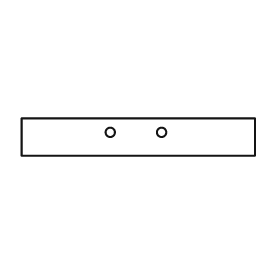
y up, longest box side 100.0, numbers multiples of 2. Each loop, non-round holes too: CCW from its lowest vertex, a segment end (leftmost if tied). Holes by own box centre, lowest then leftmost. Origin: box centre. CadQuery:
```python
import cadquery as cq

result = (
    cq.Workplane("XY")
    .moveTo(-50.0, -8.0)
    .lineTo(50.0, -8.0)
    .lineTo(50.0, 8.0)
    .lineTo(-50.0, 8.0)
    .close()
    .moveTo(-12.0, 2.0)
    .circle(2.0)
    .moveTo(10.0, 2.0)
    .circle(2.0)
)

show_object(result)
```